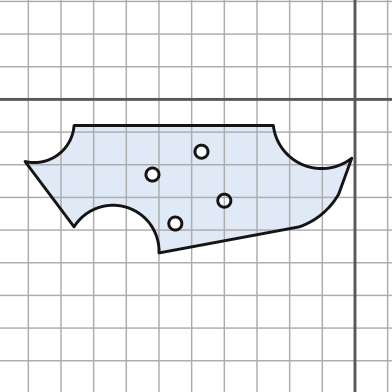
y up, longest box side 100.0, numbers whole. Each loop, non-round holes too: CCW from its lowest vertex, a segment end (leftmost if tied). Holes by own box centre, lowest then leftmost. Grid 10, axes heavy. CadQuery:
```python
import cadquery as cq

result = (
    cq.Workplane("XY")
    .moveTo(-60.0, -47.0)
    .lineTo(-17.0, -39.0)
    .threePointArc((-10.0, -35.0), (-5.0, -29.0))
    .lineTo(-1.0, -18.0)
    .threePointArc((-16.0, -20.0), (-25.0, -8.0))
    .lineTo(-86.0, -8.0)
    .threePointArc((-91.0, -17.0), (-101.0, -19.0))
    .lineTo(-86.0, -39.0)
    .threePointArc((-70.0, -33.0), (-60.0, -47.0))
    .close()
    .moveTo(-55.0, -38.0)
    .circle(2.0)
    .moveTo(-40.0, -31.0)
    .circle(2.0)
    .moveTo(-62.0, -23.0)
    .circle(2.0)
    .moveTo(-47.0, -16.0)
    .circle(2.0)
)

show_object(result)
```